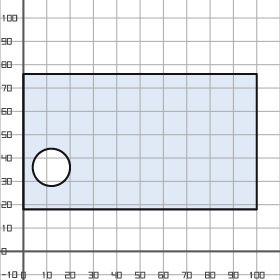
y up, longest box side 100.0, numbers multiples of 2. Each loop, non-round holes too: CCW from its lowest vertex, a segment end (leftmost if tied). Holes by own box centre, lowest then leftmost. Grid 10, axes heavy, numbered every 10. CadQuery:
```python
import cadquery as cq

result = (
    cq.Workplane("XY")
    .moveTo(0.0, 18.0)
    .lineTo(100.0, 18.0)
    .lineTo(100.0, 76.0)
    .lineTo(0.0, 76.0)
    .close()
    .moveTo(12.0, 36.0)
    .circle(8.0)
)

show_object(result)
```